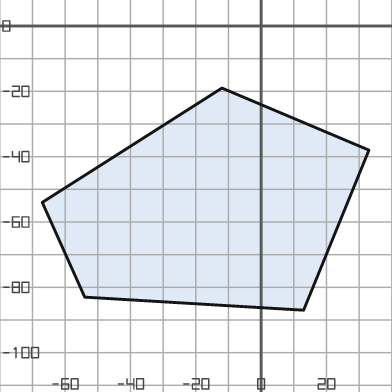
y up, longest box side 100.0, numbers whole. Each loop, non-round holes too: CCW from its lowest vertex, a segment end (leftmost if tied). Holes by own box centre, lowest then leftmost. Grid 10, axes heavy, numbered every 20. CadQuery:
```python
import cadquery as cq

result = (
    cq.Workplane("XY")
    .moveTo(13.0, -87.0)
    .lineTo(33.0, -38.0)
    .lineTo(-12.0, -19.0)
    .lineTo(-67.0, -54.0)
    .lineTo(-54.0, -83.0)
    .close()
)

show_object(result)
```